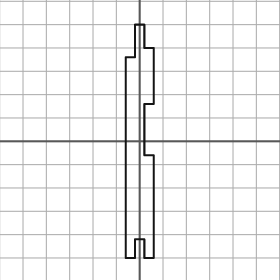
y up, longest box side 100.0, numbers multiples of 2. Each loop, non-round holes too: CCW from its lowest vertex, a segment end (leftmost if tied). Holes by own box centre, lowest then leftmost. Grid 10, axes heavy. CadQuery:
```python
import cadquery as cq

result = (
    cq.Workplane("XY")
    .moveTo(-6.0, -50.0)
    .lineTo(-2.0, -50.0)
    .lineTo(-2.0, -42.0)
    .lineTo(2.0, -42.0)
    .lineTo(2.0, -50.0)
    .lineTo(6.0, -50.0)
    .lineTo(6.0, -6.0)
    .lineTo(2.0, -6.0)
    .lineTo(2.0, 16.0)
    .lineTo(6.0, 16.0)
    .lineTo(6.0, 40.0)
    .lineTo(2.0, 40.0)
    .lineTo(2.0, 50.0)
    .lineTo(-2.0, 50.0)
    .lineTo(-2.0, 36.0)
    .lineTo(-6.0, 36.0)
    .close()
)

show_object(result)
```